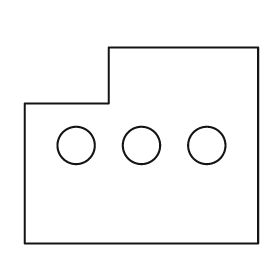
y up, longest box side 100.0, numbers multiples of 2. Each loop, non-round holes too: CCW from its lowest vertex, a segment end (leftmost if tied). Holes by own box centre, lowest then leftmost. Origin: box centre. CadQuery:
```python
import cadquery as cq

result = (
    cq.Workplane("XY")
    .moveTo(-50.0, -42.0)
    .lineTo(50.0, -42.0)
    .lineTo(50.0, 42.0)
    .lineTo(-14.0, 42.0)
    .lineTo(-14.0, 18.0)
    .lineTo(-50.0, 18.0)
    .close()
    .moveTo(-28.0, 0.0)
    .circle(8.0)
    .moveTo(0.0, 0.0)
    .circle(8.0)
    .moveTo(28.0, 0.0)
    .circle(8.0)
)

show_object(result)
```